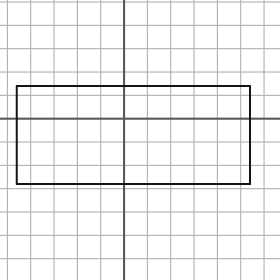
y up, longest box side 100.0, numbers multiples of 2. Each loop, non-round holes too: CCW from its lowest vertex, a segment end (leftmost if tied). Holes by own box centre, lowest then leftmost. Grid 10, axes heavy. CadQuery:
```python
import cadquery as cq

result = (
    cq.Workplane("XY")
    .moveTo(-46.0, -28.0)
    .lineTo(54.0, -28.0)
    .lineTo(54.0, 14.0)
    .lineTo(-46.0, 14.0)
    .close()
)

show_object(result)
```